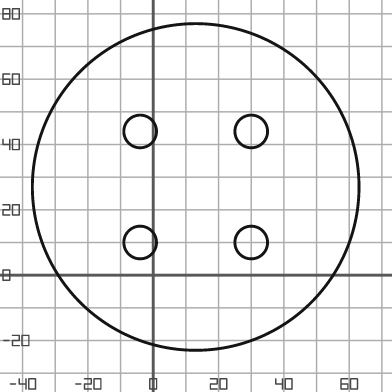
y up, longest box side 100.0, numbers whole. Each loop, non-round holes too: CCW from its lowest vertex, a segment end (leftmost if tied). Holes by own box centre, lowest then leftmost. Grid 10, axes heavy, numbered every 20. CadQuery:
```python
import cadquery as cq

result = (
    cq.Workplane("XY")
    .moveTo(13.0, 27.0)
    .circle(50.0)
    .moveTo(-4.0, 10.0)
    .circle(5.0)
    .moveTo(30.0, 10.0)
    .circle(5.0)
    .moveTo(-4.0, 44.0)
    .circle(5.0)
    .moveTo(30.0, 44.0)
    .circle(5.0)
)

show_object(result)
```